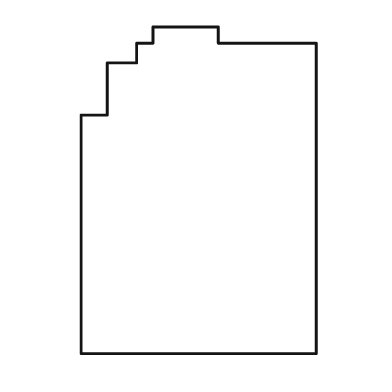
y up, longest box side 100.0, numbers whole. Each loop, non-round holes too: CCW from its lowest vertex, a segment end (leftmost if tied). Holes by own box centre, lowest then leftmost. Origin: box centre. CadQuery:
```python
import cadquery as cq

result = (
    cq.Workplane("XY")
    .moveTo(-36.0, -50.0)
    .lineTo(36.0, -50.0)
    .lineTo(36.0, 45.0)
    .lineTo(6.0, 45.0)
    .lineTo(6.0, 50.0)
    .lineTo(-14.0, 50.0)
    .lineTo(-14.0, 45.0)
    .lineTo(-19.0, 45.0)
    .lineTo(-19.0, 39.0)
    .lineTo(-28.0, 39.0)
    .lineTo(-28.0, 23.0)
    .lineTo(-36.0, 23.0)
    .close()
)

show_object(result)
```